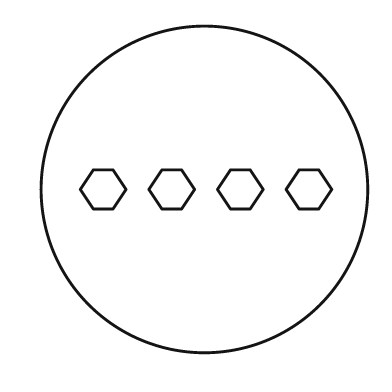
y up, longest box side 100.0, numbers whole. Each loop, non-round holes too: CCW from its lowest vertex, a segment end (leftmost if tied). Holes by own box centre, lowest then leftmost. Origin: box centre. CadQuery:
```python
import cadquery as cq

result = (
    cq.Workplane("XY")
    .moveTo(0.0, 0.0)
    .circle(50.0)
    .moveTo(-34.0, -6.0)
    .lineTo(-28.0, -6.0)
    .lineTo(-24.0, 0.0)
    .lineTo(-28.0, 6.0)
    .lineTo(-34.0, 6.0)
    .lineTo(-38.0, 0.0)
    .close()
    .moveTo(-13.0, -6.0)
    .lineTo(-7.0, -6.0)
    .lineTo(-3.0, 0.0)
    .lineTo(-7.0, 6.0)
    .lineTo(-13.0, 6.0)
    .lineTo(-17.0, 0.0)
    .close()
    .moveTo(8.0, -6.0)
    .lineTo(14.0, -6.0)
    .lineTo(18.0, 0.0)
    .lineTo(14.0, 6.0)
    .lineTo(8.0, 6.0)
    .lineTo(4.0, 0.0)
    .close()
    .moveTo(29.0, -6.0)
    .lineTo(35.0, -6.0)
    .lineTo(39.0, 0.0)
    .lineTo(35.0, 6.0)
    .lineTo(29.0, 6.0)
    .lineTo(25.0, 0.0)
    .close()
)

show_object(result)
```